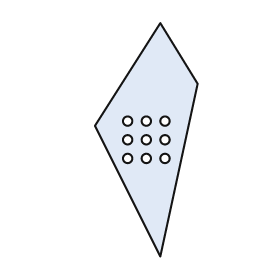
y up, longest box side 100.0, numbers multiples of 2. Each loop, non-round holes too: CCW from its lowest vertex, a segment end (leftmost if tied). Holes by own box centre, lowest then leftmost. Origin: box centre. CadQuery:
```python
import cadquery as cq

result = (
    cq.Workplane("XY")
    .moveTo(6.0, -50.0)
    .lineTo(22.0, 24.0)
    .lineTo(6.0, 50.0)
    .lineTo(-22.0, 6.0)
    .close()
    .moveTo(-8.0, -8.0)
    .circle(2.0)
    .moveTo(0.0, -8.0)
    .circle(2.0)
    .moveTo(8.0, -8.0)
    .circle(2.0)
    .moveTo(-8.0, 0.0)
    .circle(2.0)
    .moveTo(0.0, 0.0)
    .circle(2.0)
    .moveTo(8.0, 0.0)
    .circle(2.0)
    .moveTo(-8.0, 8.0)
    .circle(2.0)
    .moveTo(0.0, 8.0)
    .circle(2.0)
    .moveTo(8.0, 8.0)
    .circle(2.0)
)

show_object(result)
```